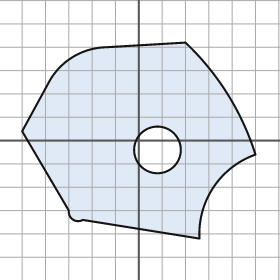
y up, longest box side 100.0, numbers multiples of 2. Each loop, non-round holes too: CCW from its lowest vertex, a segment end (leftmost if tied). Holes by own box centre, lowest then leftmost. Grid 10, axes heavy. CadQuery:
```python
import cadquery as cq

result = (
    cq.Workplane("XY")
    .moveTo(26.0, -42.0)
    .threePointArc((32.0, -20.0), (50.0, -6.0))
    .threePointArc((38.0, 20.0), (20.0, 42.0))
    .lineTo(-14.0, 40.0)
    .threePointArc((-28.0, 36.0), (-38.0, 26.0))
    .lineTo(-50.0, 4.0)
    .lineTo(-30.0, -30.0)
    .threePointArc((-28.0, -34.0), (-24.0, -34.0))
    .close()
    .moveTo(8.0, -4.0)
    .circle(10.0)
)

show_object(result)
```